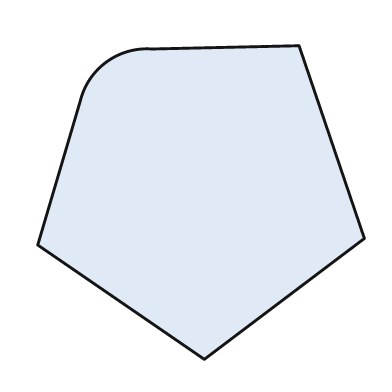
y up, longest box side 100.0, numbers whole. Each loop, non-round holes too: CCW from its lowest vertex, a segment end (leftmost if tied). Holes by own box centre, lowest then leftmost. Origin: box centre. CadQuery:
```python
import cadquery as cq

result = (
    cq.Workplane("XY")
    .moveTo(1.0, -48.0)
    .lineTo(50.0, -11.0)
    .lineTo(30.0, 48.0)
    .lineTo(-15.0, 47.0)
    .threePointArc((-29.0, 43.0), (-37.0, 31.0))
    .lineTo(-50.0, -13.0)
    .close()
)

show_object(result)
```